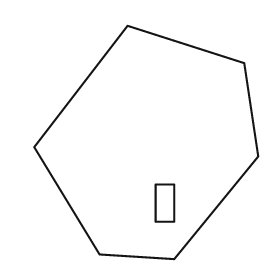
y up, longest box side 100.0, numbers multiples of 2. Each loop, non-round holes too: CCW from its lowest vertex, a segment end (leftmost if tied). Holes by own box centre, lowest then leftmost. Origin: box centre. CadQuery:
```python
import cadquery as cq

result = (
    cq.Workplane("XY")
    .moveTo(12.0, -50.0)
    .lineTo(48.0, -6.0)
    .lineTo(42.0, 34.0)
    .lineTo(-8.0, 50.0)
    .lineTo(-48.0, -2.0)
    .lineTo(-20.0, -48.0)
    .close()
    .moveTo(4.0, -34.0)
    .lineTo(12.0, -34.0)
    .lineTo(12.0, -18.0)
    .lineTo(4.0, -18.0)
    .close()
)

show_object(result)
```